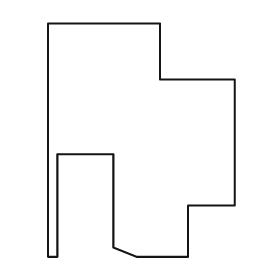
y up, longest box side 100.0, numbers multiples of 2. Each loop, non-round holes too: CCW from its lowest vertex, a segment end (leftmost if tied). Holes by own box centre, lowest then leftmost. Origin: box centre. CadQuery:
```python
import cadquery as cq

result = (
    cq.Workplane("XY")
    .moveTo(-40.0, -50.0)
    .lineTo(-36.0, -50.0)
    .lineTo(-36.0, -6.0)
    .lineTo(-12.0, -6.0)
    .lineTo(-12.0, -46.0)
    .lineTo(-2.0, -50.0)
    .lineTo(20.0, -50.0)
    .lineTo(20.0, -28.0)
    .lineTo(40.0, -28.0)
    .lineTo(40.0, 26.0)
    .lineTo(8.0, 26.0)
    .lineTo(8.0, 50.0)
    .lineTo(-40.0, 50.0)
    .close()
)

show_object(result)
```